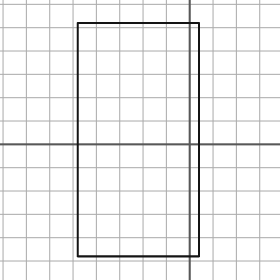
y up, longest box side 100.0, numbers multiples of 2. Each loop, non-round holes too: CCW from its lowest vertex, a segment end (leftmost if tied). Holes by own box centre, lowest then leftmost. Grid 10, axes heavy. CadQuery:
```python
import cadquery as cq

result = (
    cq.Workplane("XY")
    .moveTo(-48.0, -48.0)
    .lineTo(4.0, -48.0)
    .lineTo(4.0, 52.0)
    .lineTo(-48.0, 52.0)
    .close()
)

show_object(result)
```